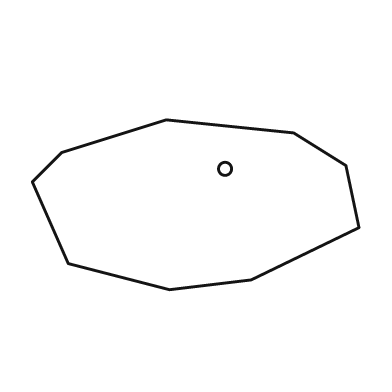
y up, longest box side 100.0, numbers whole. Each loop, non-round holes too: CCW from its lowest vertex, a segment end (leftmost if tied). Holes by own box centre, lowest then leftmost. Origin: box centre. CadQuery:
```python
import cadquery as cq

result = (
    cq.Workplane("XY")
    .moveTo(-8.0, -26.0)
    .lineTo(17.0, -23.0)
    .lineTo(50.0, -7.0)
    .lineTo(46.0, 12.0)
    .lineTo(30.0, 22.0)
    .lineTo(-9.0, 26.0)
    .lineTo(-41.0, 16.0)
    .lineTo(-50.0, 7.0)
    .lineTo(-39.0, -18.0)
    .close()
    .moveTo(9.0, 11.0)
    .circle(2.0)
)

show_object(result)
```